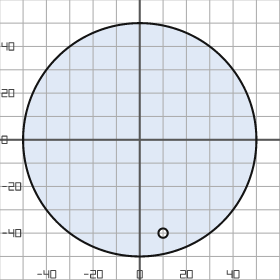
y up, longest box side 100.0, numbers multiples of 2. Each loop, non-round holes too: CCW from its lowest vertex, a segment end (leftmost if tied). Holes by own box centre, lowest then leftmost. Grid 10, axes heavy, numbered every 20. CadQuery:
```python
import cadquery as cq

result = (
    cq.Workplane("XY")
    .moveTo(0.0, 0.0)
    .circle(50.0)
    .moveTo(10.0, -40.0)
    .circle(2.0)
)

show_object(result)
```